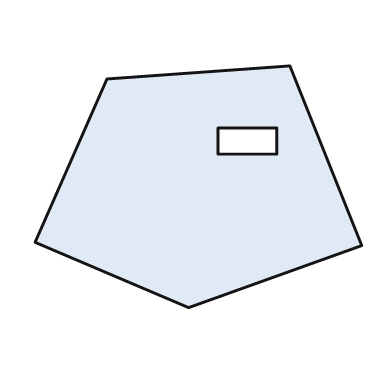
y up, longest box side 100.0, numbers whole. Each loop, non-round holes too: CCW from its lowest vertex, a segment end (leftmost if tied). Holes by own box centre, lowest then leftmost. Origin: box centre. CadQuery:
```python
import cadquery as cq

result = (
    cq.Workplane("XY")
    .moveTo(-3.0, -37.0)
    .lineTo(50.0, -18.0)
    .lineTo(28.0, 37.0)
    .lineTo(-28.0, 33.0)
    .lineTo(-50.0, -17.0)
    .close()
    .moveTo(6.0, 10.0)
    .lineTo(24.0, 10.0)
    .lineTo(24.0, 18.0)
    .lineTo(6.0, 18.0)
    .close()
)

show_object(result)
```